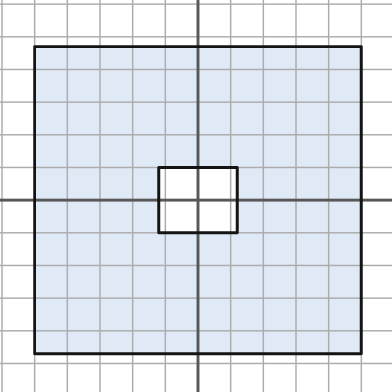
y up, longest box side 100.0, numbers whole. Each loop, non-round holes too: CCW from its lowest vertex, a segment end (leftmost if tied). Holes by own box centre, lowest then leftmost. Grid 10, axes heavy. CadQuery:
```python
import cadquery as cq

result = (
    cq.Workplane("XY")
    .moveTo(-50.0, -47.0)
    .lineTo(50.0, -47.0)
    .lineTo(50.0, 47.0)
    .lineTo(-50.0, 47.0)
    .close()
    .moveTo(-12.0, -10.0)
    .lineTo(12.0, -10.0)
    .lineTo(12.0, 10.0)
    .lineTo(-12.0, 10.0)
    .close()
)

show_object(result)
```